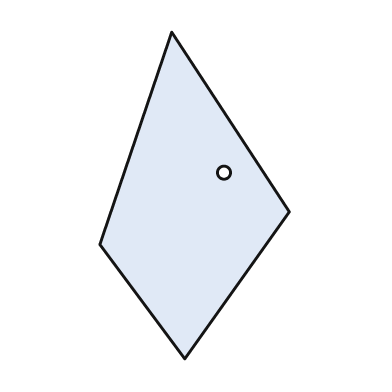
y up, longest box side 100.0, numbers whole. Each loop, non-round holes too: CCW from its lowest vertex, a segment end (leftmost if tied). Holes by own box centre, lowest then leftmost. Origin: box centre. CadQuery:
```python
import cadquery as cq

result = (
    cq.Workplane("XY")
    .moveTo(-3.0, -50.0)
    .lineTo(29.0, -5.0)
    .lineTo(-7.0, 50.0)
    .lineTo(-29.0, -15.0)
    .close()
    .moveTo(9.0, 7.0)
    .circle(2.0)
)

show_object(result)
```